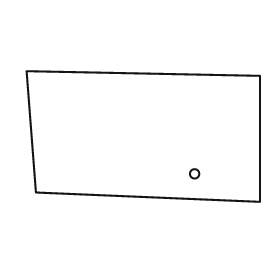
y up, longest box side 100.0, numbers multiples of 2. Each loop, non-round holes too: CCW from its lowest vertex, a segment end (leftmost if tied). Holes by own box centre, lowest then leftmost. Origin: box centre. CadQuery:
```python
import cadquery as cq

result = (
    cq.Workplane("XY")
    .moveTo(50.0, -28.0)
    .lineTo(50.0, 26.0)
    .lineTo(-50.0, 28.0)
    .lineTo(-46.0, -24.0)
    .close()
    .moveTo(22.0, -16.0)
    .circle(2.0)
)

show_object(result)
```